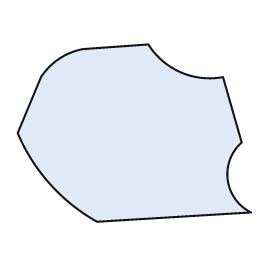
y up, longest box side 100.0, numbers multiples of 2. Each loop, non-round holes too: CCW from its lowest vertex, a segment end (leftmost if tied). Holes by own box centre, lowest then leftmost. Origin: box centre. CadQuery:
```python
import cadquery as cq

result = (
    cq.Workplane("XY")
    .moveTo(-16.0, -38.0)
    .lineTo(50.0, -34.0)
    .threePointArc((40.0, -20.0), (46.0, -4.0))
    .lineTo(38.0, 24.0)
    .threePointArc((20.0, 26.0), (6.0, 38.0))
    .lineTo(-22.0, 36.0)
    .threePointArc((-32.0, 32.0), (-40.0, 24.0))
    .lineTo(-50.0, 0.0)
    .threePointArc((-36.0, -22.0), (-16.0, -38.0))
    .close()
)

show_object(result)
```